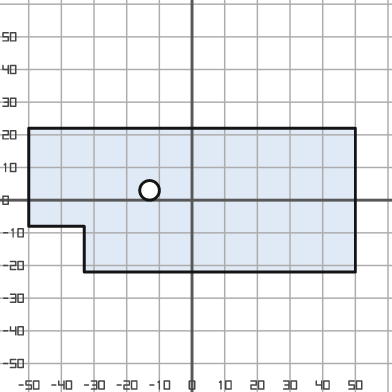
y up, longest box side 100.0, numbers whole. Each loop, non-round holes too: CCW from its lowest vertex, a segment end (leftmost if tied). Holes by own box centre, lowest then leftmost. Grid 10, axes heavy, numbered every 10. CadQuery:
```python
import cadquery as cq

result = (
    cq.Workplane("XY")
    .moveTo(-33.0, -22.0)
    .lineTo(50.0, -22.0)
    .lineTo(50.0, 22.0)
    .lineTo(-50.0, 22.0)
    .lineTo(-50.0, -8.0)
    .lineTo(-33.0, -8.0)
    .close()
    .moveTo(-13.0, 3.0)
    .circle(3.0)
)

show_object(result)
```